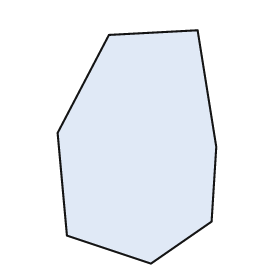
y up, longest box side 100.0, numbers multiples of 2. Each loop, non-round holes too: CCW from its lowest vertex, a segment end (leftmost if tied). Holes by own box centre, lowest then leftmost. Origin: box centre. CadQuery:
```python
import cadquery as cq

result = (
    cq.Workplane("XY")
    .moveTo(6.0, -50.0)
    .lineTo(32.0, -32.0)
    .lineTo(34.0, 0.0)
    .lineTo(26.0, 50.0)
    .lineTo(-12.0, 48.0)
    .lineTo(-34.0, 6.0)
    .lineTo(-30.0, -38.0)
    .close()
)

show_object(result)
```